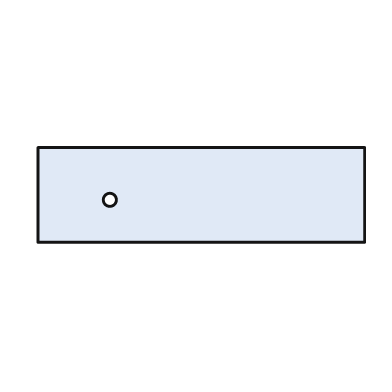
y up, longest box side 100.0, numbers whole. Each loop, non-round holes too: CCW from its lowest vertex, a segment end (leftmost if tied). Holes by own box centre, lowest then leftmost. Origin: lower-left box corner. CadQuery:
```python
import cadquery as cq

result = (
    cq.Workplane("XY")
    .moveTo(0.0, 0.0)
    .lineTo(100.0, 0.0)
    .lineTo(100.0, 29.0)
    .lineTo(0.0, 29.0)
    .close()
    .moveTo(22.0, 13.0)
    .circle(2.0)
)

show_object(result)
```